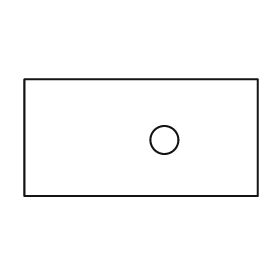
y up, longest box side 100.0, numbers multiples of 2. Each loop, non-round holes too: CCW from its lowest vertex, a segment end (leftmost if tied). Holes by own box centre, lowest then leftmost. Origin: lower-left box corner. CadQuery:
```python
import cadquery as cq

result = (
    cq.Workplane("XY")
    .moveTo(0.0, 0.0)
    .lineTo(100.0, 0.0)
    .lineTo(100.0, 50.0)
    .lineTo(0.0, 50.0)
    .close()
    .moveTo(60.0, 24.0)
    .circle(6.0)
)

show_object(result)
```